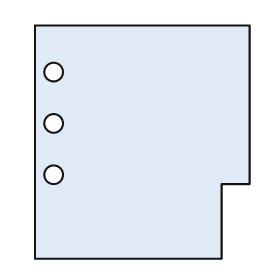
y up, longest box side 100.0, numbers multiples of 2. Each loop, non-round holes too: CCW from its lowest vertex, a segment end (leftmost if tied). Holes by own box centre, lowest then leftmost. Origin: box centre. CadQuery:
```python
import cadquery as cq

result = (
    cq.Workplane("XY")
    .moveTo(-46.0, -50.0)
    .lineTo(34.0, -50.0)
    .lineTo(34.0, -18.0)
    .lineTo(46.0, -18.0)
    .lineTo(46.0, 50.0)
    .lineTo(-46.0, 50.0)
    .close()
    .moveTo(-38.0, -14.0)
    .circle(4.0)
    .moveTo(-38.0, 8.0)
    .circle(4.0)
    .moveTo(-38.0, 30.0)
    .circle(4.0)
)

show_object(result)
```